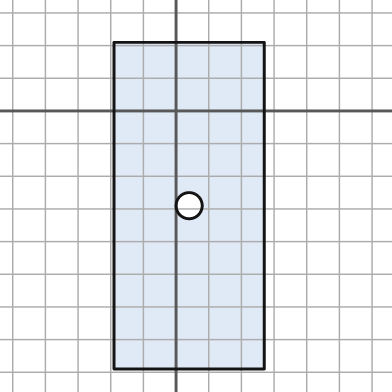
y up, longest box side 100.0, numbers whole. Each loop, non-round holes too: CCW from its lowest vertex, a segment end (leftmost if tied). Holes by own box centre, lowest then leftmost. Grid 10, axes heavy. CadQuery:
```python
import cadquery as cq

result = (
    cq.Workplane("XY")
    .moveTo(-19.0, -79.0)
    .lineTo(27.0, -79.0)
    .lineTo(27.0, 21.0)
    .lineTo(-19.0, 21.0)
    .close()
    .moveTo(4.0, -29.0)
    .circle(4.0)
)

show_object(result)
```